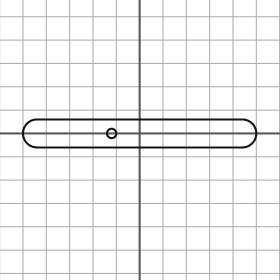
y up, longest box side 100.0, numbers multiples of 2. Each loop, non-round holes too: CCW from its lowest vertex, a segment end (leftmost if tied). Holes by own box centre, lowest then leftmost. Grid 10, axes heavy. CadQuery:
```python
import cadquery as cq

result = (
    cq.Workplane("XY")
    .moveTo(-44.0, -6.0)
    .lineTo(44.0, -6.0)
    .threePointArc((50.0, 0.0), (44.0, 6.0))
    .lineTo(-44.0, 6.0)
    .threePointArc((-50.0, 0.0), (-44.0, -6.0))
    .close()
    .moveTo(-12.0, 0.0)
    .circle(2.0)
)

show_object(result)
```